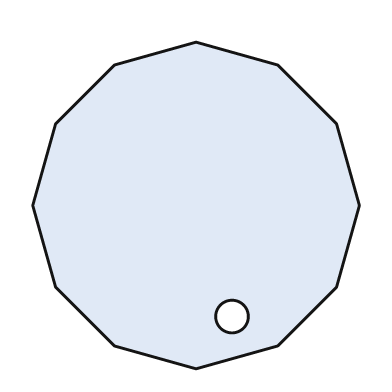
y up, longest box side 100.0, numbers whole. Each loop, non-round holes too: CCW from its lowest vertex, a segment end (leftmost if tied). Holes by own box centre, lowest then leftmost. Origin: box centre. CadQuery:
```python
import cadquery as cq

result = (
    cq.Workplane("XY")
    .moveTo(0.0, -50.0)
    .lineTo(25.0, -43.0)
    .lineTo(43.0, -25.0)
    .lineTo(50.0, 0.0)
    .lineTo(43.0, 25.0)
    .lineTo(25.0, 43.0)
    .lineTo(0.0, 50.0)
    .lineTo(-25.0, 43.0)
    .lineTo(-43.0, 25.0)
    .lineTo(-50.0, 0.0)
    .lineTo(-43.0, -25.0)
    .lineTo(-25.0, -43.0)
    .close()
    .moveTo(11.0, -34.0)
    .circle(5.0)
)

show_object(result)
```